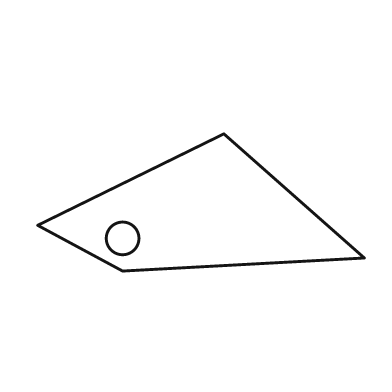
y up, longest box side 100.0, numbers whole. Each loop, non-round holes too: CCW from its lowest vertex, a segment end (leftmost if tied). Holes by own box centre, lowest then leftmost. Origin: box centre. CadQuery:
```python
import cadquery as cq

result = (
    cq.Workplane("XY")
    .moveTo(-24.0, -21.0)
    .lineTo(50.0, -17.0)
    .lineTo(7.0, 21.0)
    .lineTo(-50.0, -7.0)
    .close()
    .moveTo(-24.0, -11.0)
    .circle(5.0)
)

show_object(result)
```